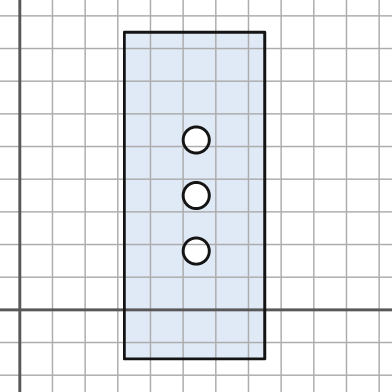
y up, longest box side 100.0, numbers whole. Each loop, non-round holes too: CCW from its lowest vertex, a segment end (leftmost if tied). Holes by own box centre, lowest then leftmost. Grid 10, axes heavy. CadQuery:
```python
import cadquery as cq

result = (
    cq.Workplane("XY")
    .moveTo(32.0, -15.0)
    .lineTo(75.0, -15.0)
    .lineTo(75.0, 85.0)
    .lineTo(32.0, 85.0)
    .close()
    .moveTo(54.0, 18.0)
    .circle(4.0)
    .moveTo(54.0, 35.0)
    .circle(4.0)
    .moveTo(54.0, 52.0)
    .circle(4.0)
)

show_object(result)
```